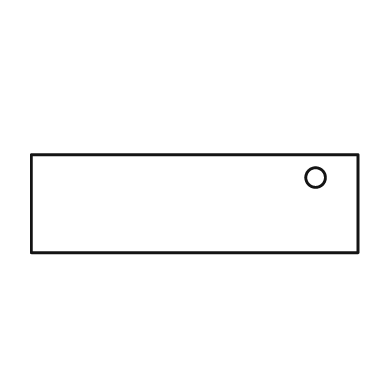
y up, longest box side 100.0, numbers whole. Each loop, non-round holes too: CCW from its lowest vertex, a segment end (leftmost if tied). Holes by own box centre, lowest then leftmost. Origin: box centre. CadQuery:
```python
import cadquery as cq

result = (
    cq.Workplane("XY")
    .moveTo(-50.0, -15.0)
    .lineTo(50.0, -15.0)
    .lineTo(50.0, 15.0)
    .lineTo(-50.0, 15.0)
    .close()
    .moveTo(37.0, 8.0)
    .circle(3.0)
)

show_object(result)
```